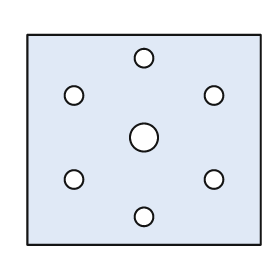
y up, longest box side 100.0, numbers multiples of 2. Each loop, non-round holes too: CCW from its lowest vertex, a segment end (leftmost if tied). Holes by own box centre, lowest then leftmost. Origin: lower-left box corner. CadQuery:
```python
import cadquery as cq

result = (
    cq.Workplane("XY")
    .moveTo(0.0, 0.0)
    .lineTo(100.0, 0.0)
    .lineTo(100.0, 90.0)
    .lineTo(0.0, 90.0)
    .close()
    .moveTo(50.0, 12.0)
    .circle(4.0)
    .moveTo(20.0, 28.0)
    .circle(4.0)
    .moveTo(80.0, 28.0)
    .circle(4.0)
    .moveTo(50.0, 46.0)
    .circle(6.0)
    .moveTo(20.0, 64.0)
    .circle(4.0)
    .moveTo(80.0, 64.0)
    .circle(4.0)
    .moveTo(50.0, 80.0)
    .circle(4.0)
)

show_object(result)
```